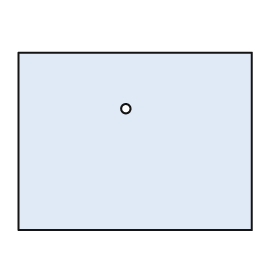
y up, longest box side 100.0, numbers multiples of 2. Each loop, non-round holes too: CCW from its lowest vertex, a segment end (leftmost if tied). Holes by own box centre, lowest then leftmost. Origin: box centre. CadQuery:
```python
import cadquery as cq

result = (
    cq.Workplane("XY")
    .moveTo(-50.0, -38.0)
    .lineTo(50.0, -38.0)
    .lineTo(50.0, 38.0)
    .lineTo(-50.0, 38.0)
    .close()
    .moveTo(-4.0, 14.0)
    .circle(2.0)
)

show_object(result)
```